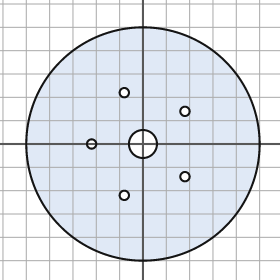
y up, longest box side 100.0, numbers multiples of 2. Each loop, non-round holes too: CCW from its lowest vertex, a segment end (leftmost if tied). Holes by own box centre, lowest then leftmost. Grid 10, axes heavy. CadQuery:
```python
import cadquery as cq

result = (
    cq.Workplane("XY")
    .moveTo(0.0, 0.0)
    .circle(50.0)
    .moveTo(-8.0, -22.0)
    .circle(2.0)
    .moveTo(18.0, -14.0)
    .circle(2.0)
    .moveTo(-22.0, 0.0)
    .circle(2.0)
    .moveTo(0.0, 0.0)
    .circle(6.0)
    .moveTo(18.0, 14.0)
    .circle(2.0)
    .moveTo(-8.0, 22.0)
    .circle(2.0)
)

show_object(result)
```